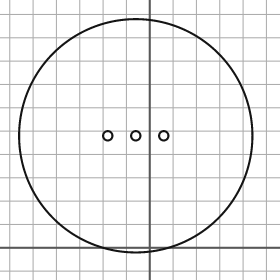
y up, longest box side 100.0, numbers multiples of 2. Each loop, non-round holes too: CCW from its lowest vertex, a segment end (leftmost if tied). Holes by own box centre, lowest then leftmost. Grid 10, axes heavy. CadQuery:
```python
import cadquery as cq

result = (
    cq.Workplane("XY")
    .moveTo(-6.0, 48.0)
    .circle(50.0)
    .moveTo(-18.0, 48.0)
    .circle(2.0)
    .moveTo(-6.0, 48.0)
    .circle(2.0)
    .moveTo(6.0, 48.0)
    .circle(2.0)
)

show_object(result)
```